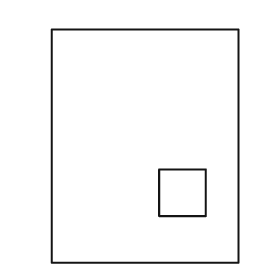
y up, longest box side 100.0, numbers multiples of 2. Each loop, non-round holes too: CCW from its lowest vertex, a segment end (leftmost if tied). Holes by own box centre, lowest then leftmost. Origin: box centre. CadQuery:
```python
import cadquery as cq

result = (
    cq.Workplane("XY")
    .moveTo(-40.0, -50.0)
    .lineTo(40.0, -50.0)
    .lineTo(40.0, 50.0)
    .lineTo(-40.0, 50.0)
    .close()
    .moveTo(6.0, -30.0)
    .lineTo(26.0, -30.0)
    .lineTo(26.0, -10.0)
    .lineTo(6.0, -10.0)
    .close()
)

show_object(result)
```